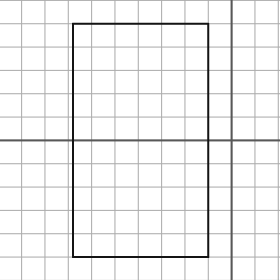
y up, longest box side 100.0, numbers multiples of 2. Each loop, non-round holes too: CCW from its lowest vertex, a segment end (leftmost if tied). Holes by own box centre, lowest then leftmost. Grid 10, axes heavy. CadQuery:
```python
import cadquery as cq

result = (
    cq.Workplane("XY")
    .moveTo(-68.0, -50.0)
    .lineTo(-10.0, -50.0)
    .lineTo(-10.0, 50.0)
    .lineTo(-68.0, 50.0)
    .close()
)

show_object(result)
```